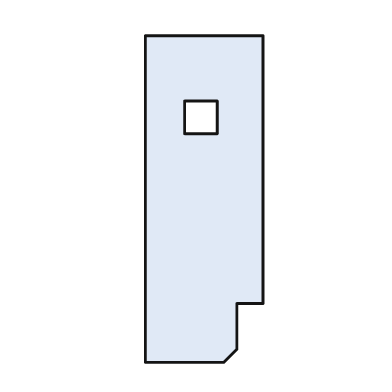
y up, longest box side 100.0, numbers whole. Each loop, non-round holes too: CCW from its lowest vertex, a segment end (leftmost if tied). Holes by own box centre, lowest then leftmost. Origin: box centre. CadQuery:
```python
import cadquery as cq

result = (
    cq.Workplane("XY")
    .moveTo(-18.0, -50.0)
    .lineTo(6.0, -50.0)
    .lineTo(10.0, -46.0)
    .lineTo(10.0, -32.0)
    .lineTo(18.0, -32.0)
    .lineTo(18.0, 50.0)
    .lineTo(-18.0, 50.0)
    .close()
    .moveTo(-6.0, 20.0)
    .lineTo(4.0, 20.0)
    .lineTo(4.0, 30.0)
    .lineTo(-6.0, 30.0)
    .close()
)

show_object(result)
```